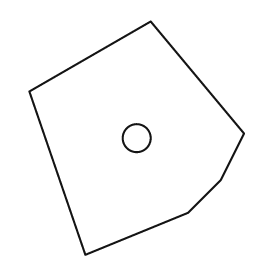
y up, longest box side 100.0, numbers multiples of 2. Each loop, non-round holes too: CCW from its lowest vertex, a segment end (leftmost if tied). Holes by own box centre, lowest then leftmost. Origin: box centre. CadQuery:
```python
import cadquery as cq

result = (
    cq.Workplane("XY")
    .moveTo(-22.0, -50.0)
    .lineTo(22.0, -32.0)
    .lineTo(36.0, -18.0)
    .lineTo(46.0, 2.0)
    .lineTo(6.0, 50.0)
    .lineTo(-46.0, 20.0)
    .close()
    .moveTo(0.0, 0.0)
    .circle(6.0)
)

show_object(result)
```